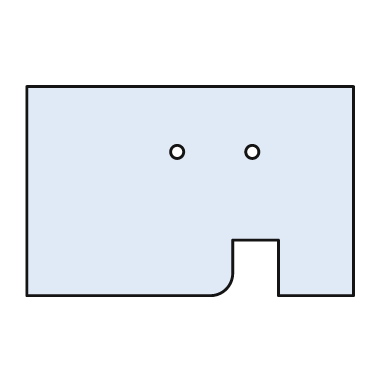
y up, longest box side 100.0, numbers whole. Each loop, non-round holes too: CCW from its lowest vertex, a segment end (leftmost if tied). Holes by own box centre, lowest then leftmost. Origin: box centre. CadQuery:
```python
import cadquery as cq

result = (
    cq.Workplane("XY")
    .moveTo(-50.0, -32.0)
    .lineTo(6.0, -32.0)
    .threePointArc((11.0, -30.0), (13.0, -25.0))
    .lineTo(13.0, -15.0)
    .lineTo(27.0, -15.0)
    .lineTo(27.0, -32.0)
    .lineTo(50.0, -32.0)
    .lineTo(50.0, 32.0)
    .lineTo(-50.0, 32.0)
    .close()
    .moveTo(-4.0, 12.0)
    .circle(2.0)
    .moveTo(19.0, 12.0)
    .circle(2.0)
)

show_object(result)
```